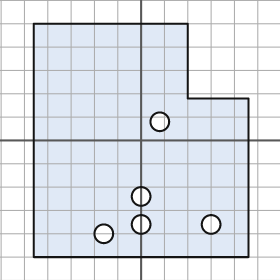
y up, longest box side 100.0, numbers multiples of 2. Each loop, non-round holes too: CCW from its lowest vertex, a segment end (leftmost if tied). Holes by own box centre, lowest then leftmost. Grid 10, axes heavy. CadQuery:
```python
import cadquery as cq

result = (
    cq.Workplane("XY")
    .moveTo(-46.0, -50.0)
    .lineTo(46.0, -50.0)
    .lineTo(46.0, 18.0)
    .lineTo(20.0, 18.0)
    .lineTo(20.0, 50.0)
    .lineTo(-46.0, 50.0)
    .close()
    .moveTo(-16.0, -40.0)
    .circle(4.0)
    .moveTo(0.0, -36.0)
    .circle(4.0)
    .moveTo(30.0, -36.0)
    .circle(4.0)
    .moveTo(0.0, -24.0)
    .circle(4.0)
    .moveTo(8.0, 8.0)
    .circle(4.0)
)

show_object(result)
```